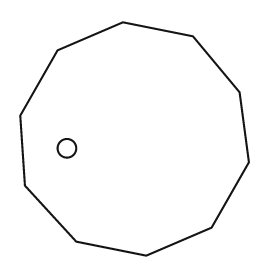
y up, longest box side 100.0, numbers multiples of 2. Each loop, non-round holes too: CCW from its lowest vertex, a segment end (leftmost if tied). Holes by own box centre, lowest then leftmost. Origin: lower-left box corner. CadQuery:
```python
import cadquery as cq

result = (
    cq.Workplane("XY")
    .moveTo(54.0, 0.0)
    .lineTo(82.0, 12.0)
    .lineTo(98.0, 40.0)
    .lineTo(94.0, 70.0)
    .lineTo(74.0, 94.0)
    .lineTo(44.0, 100.0)
    .lineTo(16.0, 88.0)
    .lineTo(0.0, 60.0)
    .lineTo(2.0, 30.0)
    .lineTo(24.0, 6.0)
    .close()
    .moveTo(20.0, 46.0)
    .circle(4.0)
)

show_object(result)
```